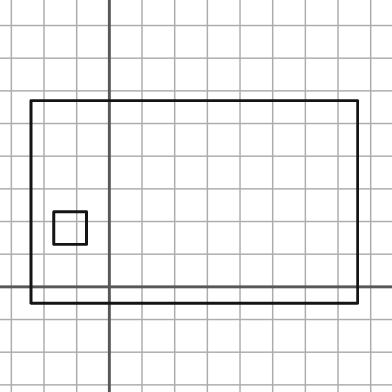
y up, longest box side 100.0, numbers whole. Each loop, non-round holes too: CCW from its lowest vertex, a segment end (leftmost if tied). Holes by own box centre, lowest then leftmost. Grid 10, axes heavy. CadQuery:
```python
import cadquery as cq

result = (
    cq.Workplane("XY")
    .moveTo(-24.0, -5.0)
    .lineTo(76.0, -5.0)
    .lineTo(76.0, 57.0)
    .lineTo(-24.0, 57.0)
    .close()
    .moveTo(-17.0, 13.0)
    .lineTo(-7.0, 13.0)
    .lineTo(-7.0, 23.0)
    .lineTo(-17.0, 23.0)
    .close()
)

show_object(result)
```